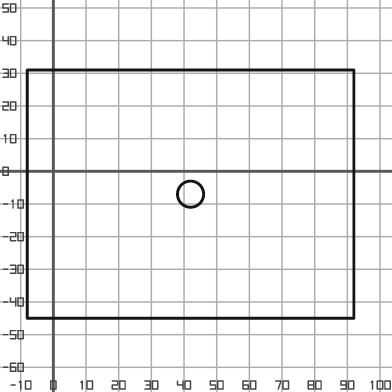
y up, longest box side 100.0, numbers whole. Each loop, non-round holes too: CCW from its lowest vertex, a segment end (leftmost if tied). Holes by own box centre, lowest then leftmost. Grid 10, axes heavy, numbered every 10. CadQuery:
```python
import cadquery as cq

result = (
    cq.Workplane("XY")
    .moveTo(-8.0, -45.0)
    .lineTo(92.0, -45.0)
    .lineTo(92.0, 31.0)
    .lineTo(-8.0, 31.0)
    .close()
    .moveTo(42.0, -7.0)
    .circle(4.0)
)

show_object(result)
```